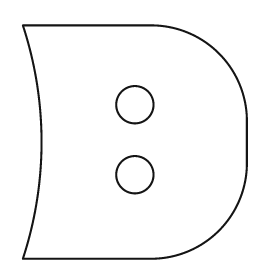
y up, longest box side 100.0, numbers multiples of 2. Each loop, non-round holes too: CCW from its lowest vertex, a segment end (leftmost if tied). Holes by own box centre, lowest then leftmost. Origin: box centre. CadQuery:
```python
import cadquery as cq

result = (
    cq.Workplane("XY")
    .moveTo(-48.0, -50.0)
    .lineTo(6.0, -50.0)
    .threePointArc((36.0, -38.0), (48.0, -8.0))
    .lineTo(48.0, 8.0)
    .threePointArc((36.0, 38.0), (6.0, 50.0))
    .lineTo(-48.0, 50.0)
    .threePointArc((-40.0, 0.0), (-48.0, -50.0))
    .close()
    .moveTo(0.0, -14.0)
    .circle(8.0)
    .moveTo(0.0, 16.0)
    .circle(8.0)
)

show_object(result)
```